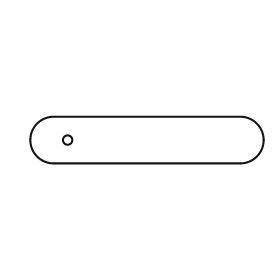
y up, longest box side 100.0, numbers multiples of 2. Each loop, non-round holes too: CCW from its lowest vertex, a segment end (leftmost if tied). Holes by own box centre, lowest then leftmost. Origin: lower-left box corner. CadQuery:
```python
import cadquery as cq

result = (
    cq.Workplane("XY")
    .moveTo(10.0, 0.0)
    .lineTo(90.0, 0.0)
    .threePointArc((100.0, 10.0), (90.0, 20.0))
    .lineTo(10.0, 20.0)
    .threePointArc((0.0, 10.0), (10.0, 0.0))
    .close()
    .moveTo(16.0, 10.0)
    .circle(2.0)
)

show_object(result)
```